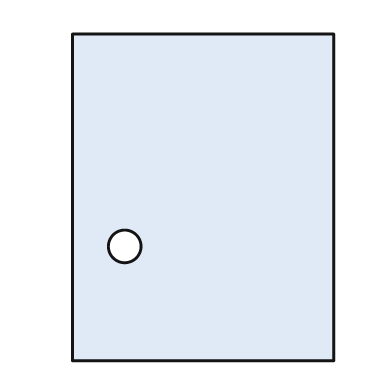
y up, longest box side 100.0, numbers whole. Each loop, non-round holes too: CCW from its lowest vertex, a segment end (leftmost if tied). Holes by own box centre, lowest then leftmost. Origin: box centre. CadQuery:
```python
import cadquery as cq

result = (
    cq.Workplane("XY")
    .moveTo(-40.0, -50.0)
    .lineTo(40.0, -50.0)
    .lineTo(40.0, 50.0)
    .lineTo(-40.0, 50.0)
    .close()
    .moveTo(-24.0, -15.0)
    .circle(5.0)
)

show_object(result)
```